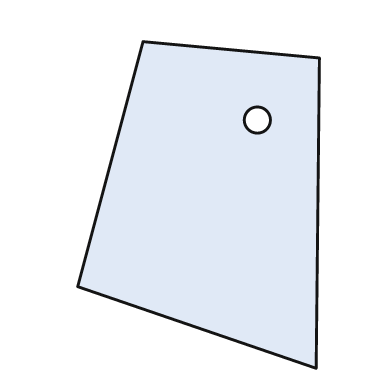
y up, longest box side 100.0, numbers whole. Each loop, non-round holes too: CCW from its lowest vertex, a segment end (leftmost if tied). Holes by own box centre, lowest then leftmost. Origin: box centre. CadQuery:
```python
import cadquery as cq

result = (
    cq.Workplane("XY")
    .moveTo(36.0, -50.0)
    .lineTo(37.0, 45.0)
    .lineTo(-17.0, 50.0)
    .lineTo(-37.0, -25.0)
    .close()
    .moveTo(18.0, 26.0)
    .circle(4.0)
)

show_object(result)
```